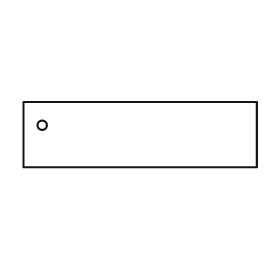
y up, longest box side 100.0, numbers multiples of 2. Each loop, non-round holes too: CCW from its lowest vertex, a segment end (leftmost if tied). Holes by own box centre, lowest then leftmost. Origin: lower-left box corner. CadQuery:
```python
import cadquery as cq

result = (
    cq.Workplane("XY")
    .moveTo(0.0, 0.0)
    .lineTo(100.0, 0.0)
    .lineTo(100.0, 28.0)
    .lineTo(0.0, 28.0)
    .close()
    .moveTo(8.0, 18.0)
    .circle(2.0)
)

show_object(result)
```